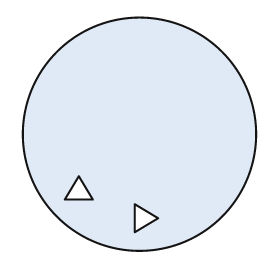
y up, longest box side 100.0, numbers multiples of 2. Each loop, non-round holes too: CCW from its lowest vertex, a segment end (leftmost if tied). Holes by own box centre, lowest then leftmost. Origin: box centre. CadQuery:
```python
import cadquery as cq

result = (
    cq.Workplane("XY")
    .moveTo(0.0, 0.0)
    .circle(50.0)
    .moveTo(-2.0, -42.0)
    .lineTo(8.0, -36.0)
    .lineTo(-2.0, -30.0)
    .close()
    .moveTo(-32.0, -28.0)
    .lineTo(-20.0, -28.0)
    .lineTo(-26.0, -18.0)
    .close()
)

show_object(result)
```